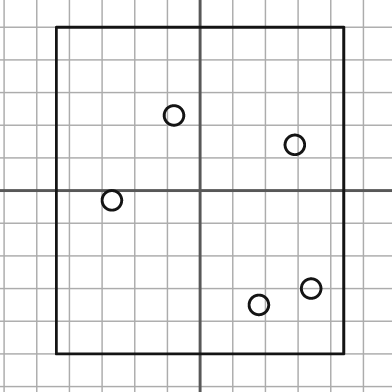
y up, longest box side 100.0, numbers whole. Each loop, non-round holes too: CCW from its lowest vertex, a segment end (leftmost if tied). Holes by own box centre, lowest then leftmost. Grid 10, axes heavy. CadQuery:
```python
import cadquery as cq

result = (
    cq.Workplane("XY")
    .moveTo(-44.0, -50.0)
    .lineTo(44.0, -50.0)
    .lineTo(44.0, 50.0)
    .lineTo(-44.0, 50.0)
    .close()
    .moveTo(18.0, -35.0)
    .circle(3.0)
    .moveTo(34.0, -30.0)
    .circle(3.0)
    .moveTo(-27.0, -3.0)
    .circle(3.0)
    .moveTo(29.0, 14.0)
    .circle(3.0)
    .moveTo(-8.0, 23.0)
    .circle(3.0)
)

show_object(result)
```